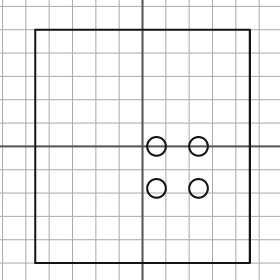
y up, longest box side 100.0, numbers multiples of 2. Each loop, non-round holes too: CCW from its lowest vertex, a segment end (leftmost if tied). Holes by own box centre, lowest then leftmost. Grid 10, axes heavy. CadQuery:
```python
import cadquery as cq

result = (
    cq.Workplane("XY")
    .moveTo(-46.0, -50.0)
    .lineTo(46.0, -50.0)
    .lineTo(46.0, 50.0)
    .lineTo(-46.0, 50.0)
    .close()
    .moveTo(6.0, -18.0)
    .circle(4.0)
    .moveTo(24.0, -18.0)
    .circle(4.0)
    .moveTo(6.0, 0.0)
    .circle(4.0)
    .moveTo(24.0, 0.0)
    .circle(4.0)
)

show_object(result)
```